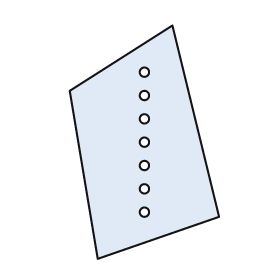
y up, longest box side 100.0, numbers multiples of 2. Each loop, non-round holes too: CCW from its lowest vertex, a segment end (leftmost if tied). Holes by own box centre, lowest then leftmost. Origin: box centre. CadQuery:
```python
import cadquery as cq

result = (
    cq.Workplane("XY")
    .moveTo(-20.0, -50.0)
    .lineTo(32.0, -32.0)
    .lineTo(12.0, 50.0)
    .lineTo(-32.0, 22.0)
    .close()
    .moveTo(0.0, -30.0)
    .circle(2.0)
    .moveTo(0.0, -20.0)
    .circle(2.0)
    .moveTo(0.0, -10.0)
    .circle(2.0)
    .moveTo(0.0, 0.0)
    .circle(2.0)
    .moveTo(0.0, 10.0)
    .circle(2.0)
    .moveTo(0.0, 20.0)
    .circle(2.0)
    .moveTo(0.0, 30.0)
    .circle(2.0)
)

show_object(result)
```